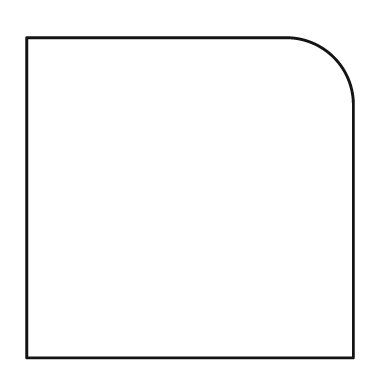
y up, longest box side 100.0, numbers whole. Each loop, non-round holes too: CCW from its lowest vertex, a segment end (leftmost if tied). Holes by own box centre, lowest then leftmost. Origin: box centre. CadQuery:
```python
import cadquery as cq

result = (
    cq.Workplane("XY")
    .moveTo(-50.0, -49.0)
    .lineTo(50.0, -49.0)
    .lineTo(50.0, 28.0)
    .threePointArc((44.0, 43.0), (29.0, 49.0))
    .lineTo(-50.0, 49.0)
    .close()
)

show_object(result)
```